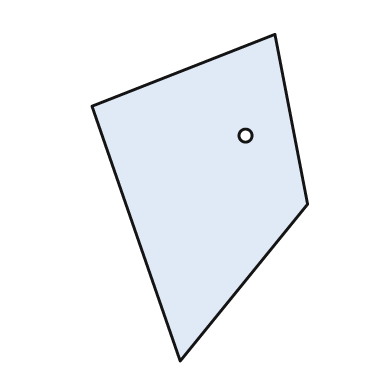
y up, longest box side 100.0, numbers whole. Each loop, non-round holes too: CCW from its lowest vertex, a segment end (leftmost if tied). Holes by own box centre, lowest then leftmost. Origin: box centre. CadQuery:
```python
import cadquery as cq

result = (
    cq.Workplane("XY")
    .moveTo(-6.0, -50.0)
    .lineTo(33.0, -2.0)
    .lineTo(23.0, 50.0)
    .lineTo(-33.0, 28.0)
    .close()
    .moveTo(14.0, 19.0)
    .circle(2.0)
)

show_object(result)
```